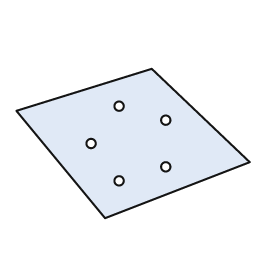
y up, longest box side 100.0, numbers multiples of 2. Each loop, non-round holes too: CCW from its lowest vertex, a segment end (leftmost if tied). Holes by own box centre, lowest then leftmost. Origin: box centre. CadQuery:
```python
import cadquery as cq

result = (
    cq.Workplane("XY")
    .moveTo(-12.0, -32.0)
    .lineTo(50.0, -8.0)
    .lineTo(8.0, 32.0)
    .lineTo(-50.0, 14.0)
    .close()
    .moveTo(-6.0, -16.0)
    .circle(2.0)
    .moveTo(14.0, -10.0)
    .circle(2.0)
    .moveTo(-18.0, 0.0)
    .circle(2.0)
    .moveTo(14.0, 10.0)
    .circle(2.0)
    .moveTo(-6.0, 16.0)
    .circle(2.0)
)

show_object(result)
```